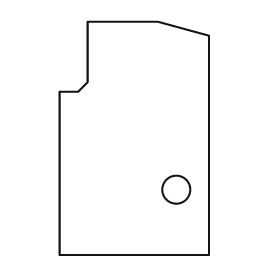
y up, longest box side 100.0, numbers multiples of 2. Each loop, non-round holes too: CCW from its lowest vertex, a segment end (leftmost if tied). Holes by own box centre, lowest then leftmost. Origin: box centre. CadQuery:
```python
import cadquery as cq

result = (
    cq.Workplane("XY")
    .moveTo(-32.0, -50.0)
    .lineTo(32.0, -50.0)
    .lineTo(32.0, 44.0)
    .lineTo(10.0, 50.0)
    .lineTo(-20.0, 50.0)
    .lineTo(-20.0, 24.0)
    .lineTo(-24.0, 20.0)
    .lineTo(-32.0, 20.0)
    .close()
    .moveTo(18.0, -22.0)
    .circle(6.0)
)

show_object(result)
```